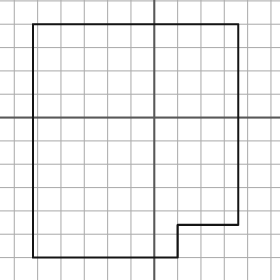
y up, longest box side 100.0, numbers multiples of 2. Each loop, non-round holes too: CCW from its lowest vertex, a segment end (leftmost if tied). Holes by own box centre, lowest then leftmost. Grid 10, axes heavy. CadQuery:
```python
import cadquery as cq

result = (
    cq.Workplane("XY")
    .moveTo(-52.0, -60.0)
    .lineTo(10.0, -60.0)
    .lineTo(10.0, -46.0)
    .lineTo(36.0, -46.0)
    .lineTo(36.0, 40.0)
    .lineTo(-52.0, 40.0)
    .close()
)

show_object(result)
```